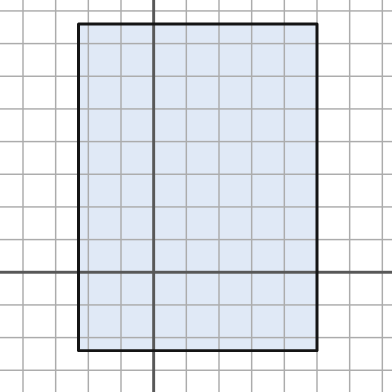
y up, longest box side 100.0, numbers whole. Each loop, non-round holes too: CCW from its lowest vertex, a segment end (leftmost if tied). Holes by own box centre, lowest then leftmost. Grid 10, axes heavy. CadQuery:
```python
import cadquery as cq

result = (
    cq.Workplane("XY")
    .moveTo(-23.0, -24.0)
    .lineTo(50.0, -24.0)
    .lineTo(50.0, 76.0)
    .lineTo(-23.0, 76.0)
    .close()
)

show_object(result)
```